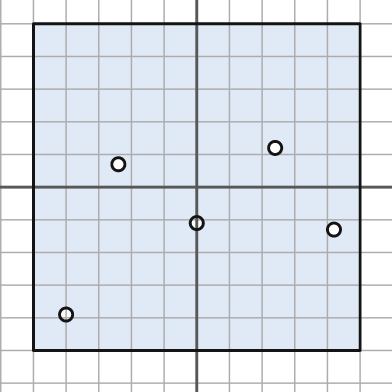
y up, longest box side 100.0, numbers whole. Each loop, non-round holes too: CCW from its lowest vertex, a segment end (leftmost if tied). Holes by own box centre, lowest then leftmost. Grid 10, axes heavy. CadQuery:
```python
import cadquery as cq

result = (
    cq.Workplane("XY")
    .moveTo(-50.0, -50.0)
    .lineTo(50.0, -50.0)
    .lineTo(50.0, 50.0)
    .lineTo(-50.0, 50.0)
    .close()
    .moveTo(-40.0, -39.0)
    .circle(2.0)
    .moveTo(42.0, -13.0)
    .circle(2.0)
    .moveTo(0.0, -11.0)
    .circle(2.0)
    .moveTo(-24.0, 7.0)
    .circle(2.0)
    .moveTo(24.0, 12.0)
    .circle(2.0)
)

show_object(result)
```